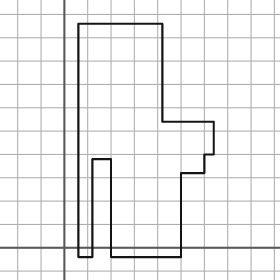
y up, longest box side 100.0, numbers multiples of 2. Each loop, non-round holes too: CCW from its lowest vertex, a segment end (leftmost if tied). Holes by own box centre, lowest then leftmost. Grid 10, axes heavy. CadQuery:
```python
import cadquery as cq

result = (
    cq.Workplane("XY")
    .moveTo(6.0, -4.0)
    .lineTo(12.0, -4.0)
    .lineTo(12.0, 38.0)
    .lineTo(20.0, 38.0)
    .lineTo(20.0, -4.0)
    .lineTo(50.0, -4.0)
    .lineTo(50.0, 32.0)
    .lineTo(60.0, 32.0)
    .lineTo(60.0, 40.0)
    .lineTo(64.0, 40.0)
    .lineTo(64.0, 54.0)
    .lineTo(42.0, 54.0)
    .lineTo(42.0, 96.0)
    .lineTo(6.0, 96.0)
    .close()
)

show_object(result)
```